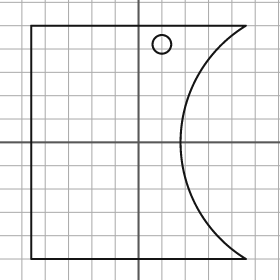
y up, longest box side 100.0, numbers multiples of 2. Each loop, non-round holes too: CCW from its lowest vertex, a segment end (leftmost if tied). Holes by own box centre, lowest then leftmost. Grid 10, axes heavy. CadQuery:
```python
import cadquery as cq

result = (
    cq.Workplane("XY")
    .moveTo(-46.0, -50.0)
    .lineTo(46.0, -50.0)
    .threePointArc((18.0, 0.0), (46.0, 50.0))
    .lineTo(-46.0, 50.0)
    .close()
    .moveTo(10.0, 42.0)
    .circle(4.0)
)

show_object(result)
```